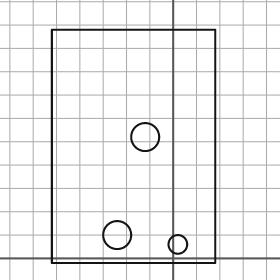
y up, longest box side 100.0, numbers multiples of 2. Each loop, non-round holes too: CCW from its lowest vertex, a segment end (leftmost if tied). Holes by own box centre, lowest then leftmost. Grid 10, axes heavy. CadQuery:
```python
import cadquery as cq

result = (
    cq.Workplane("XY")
    .moveTo(-52.0, -2.0)
    .lineTo(18.0, -2.0)
    .lineTo(18.0, 98.0)
    .lineTo(-52.0, 98.0)
    .close()
    .moveTo(2.0, 6.0)
    .circle(4.0)
    .moveTo(-24.0, 10.0)
    .circle(6.0)
    .moveTo(-12.0, 52.0)
    .circle(6.0)
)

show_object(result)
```